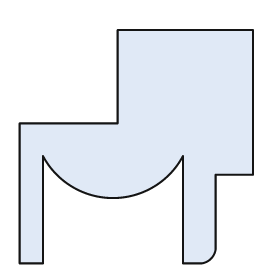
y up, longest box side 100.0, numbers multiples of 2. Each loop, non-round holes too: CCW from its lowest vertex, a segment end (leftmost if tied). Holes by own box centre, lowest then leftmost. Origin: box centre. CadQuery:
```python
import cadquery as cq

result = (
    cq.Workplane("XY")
    .moveTo(-50.0, -50.0)
    .lineTo(-40.0, -50.0)
    .lineTo(-40.0, -4.0)
    .threePointArc((-10.0, -22.0), (20.0, -4.0))
    .lineTo(20.0, -50.0)
    .lineTo(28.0, -50.0)
    .threePointArc((32.0, -48.0), (34.0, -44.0))
    .lineTo(34.0, -12.0)
    .lineTo(50.0, -12.0)
    .lineTo(50.0, 50.0)
    .lineTo(-8.0, 50.0)
    .lineTo(-8.0, 10.0)
    .lineTo(-50.0, 10.0)
    .close()
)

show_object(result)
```